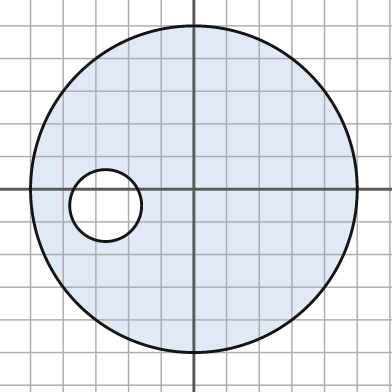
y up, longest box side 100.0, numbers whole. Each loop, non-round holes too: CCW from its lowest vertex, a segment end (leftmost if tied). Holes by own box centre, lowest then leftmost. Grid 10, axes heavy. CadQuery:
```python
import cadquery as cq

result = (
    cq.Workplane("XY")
    .moveTo(0.0, 0.0)
    .circle(50.0)
    .moveTo(-27.0, -5.0)
    .circle(11.0)
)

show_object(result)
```